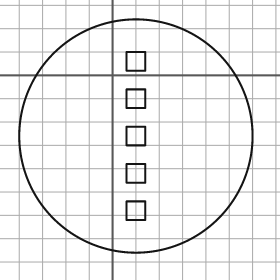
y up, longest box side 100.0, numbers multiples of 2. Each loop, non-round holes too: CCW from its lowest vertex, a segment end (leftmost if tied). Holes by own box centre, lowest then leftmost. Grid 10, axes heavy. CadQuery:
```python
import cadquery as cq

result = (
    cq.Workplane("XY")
    .moveTo(10.0, -26.0)
    .circle(50.0)
    .moveTo(6.0, -62.0)
    .lineTo(14.0, -62.0)
    .lineTo(14.0, -54.0)
    .lineTo(6.0, -54.0)
    .close()
    .moveTo(6.0, -46.0)
    .lineTo(14.0, -46.0)
    .lineTo(14.0, -38.0)
    .lineTo(6.0, -38.0)
    .close()
    .moveTo(6.0, -30.0)
    .lineTo(14.0, -30.0)
    .lineTo(14.0, -22.0)
    .lineTo(6.0, -22.0)
    .close()
    .moveTo(6.0, -14.0)
    .lineTo(14.0, -14.0)
    .lineTo(14.0, -6.0)
    .lineTo(6.0, -6.0)
    .close()
    .moveTo(6.0, 2.0)
    .lineTo(14.0, 2.0)
    .lineTo(14.0, 10.0)
    .lineTo(6.0, 10.0)
    .close()
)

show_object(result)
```